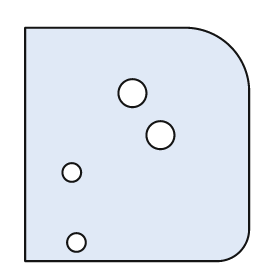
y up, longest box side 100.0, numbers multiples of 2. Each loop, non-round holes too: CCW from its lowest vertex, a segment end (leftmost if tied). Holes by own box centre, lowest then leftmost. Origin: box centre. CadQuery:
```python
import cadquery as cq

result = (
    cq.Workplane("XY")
    .moveTo(-48.0, -50.0)
    .lineTo(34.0, -50.0)
    .threePointArc((44.0, -46.0), (48.0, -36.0))
    .lineTo(48.0, 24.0)
    .threePointArc((40.0, 42.0), (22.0, 50.0))
    .lineTo(-48.0, 50.0)
    .close()
    .moveTo(-26.0, -42.0)
    .circle(4.0)
    .moveTo(-28.0, -12.0)
    .circle(4.0)
    .moveTo(10.0, 4.0)
    .circle(6.0)
    .moveTo(-2.0, 22.0)
    .circle(6.0)
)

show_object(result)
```